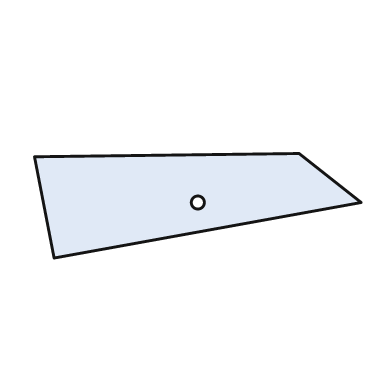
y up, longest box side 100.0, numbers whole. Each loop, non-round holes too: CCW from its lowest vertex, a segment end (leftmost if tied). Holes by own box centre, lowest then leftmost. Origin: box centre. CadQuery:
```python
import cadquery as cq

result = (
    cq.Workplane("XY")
    .moveTo(-44.0, -16.0)
    .lineTo(50.0, 1.0)
    .lineTo(31.0, 16.0)
    .lineTo(-50.0, 15.0)
    .close()
    .moveTo(0.0, 1.0)
    .circle(2.0)
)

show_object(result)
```